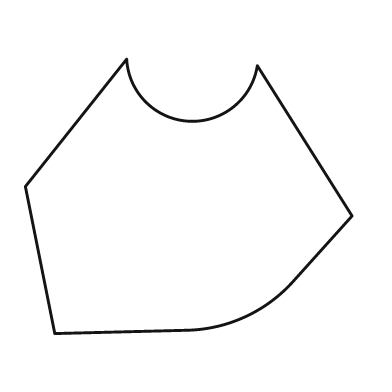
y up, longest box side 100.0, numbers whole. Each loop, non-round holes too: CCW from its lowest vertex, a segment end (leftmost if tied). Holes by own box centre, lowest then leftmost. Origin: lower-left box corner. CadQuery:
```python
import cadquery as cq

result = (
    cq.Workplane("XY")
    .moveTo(9.0, 0.0)
    .lineTo(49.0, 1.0)
    .threePointArc((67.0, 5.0), (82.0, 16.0))
    .lineTo(100.0, 36.0)
    .lineTo(71.0, 82.0)
    .threePointArc((50.0, 65.0), (31.0, 84.0))
    .lineTo(0.0, 45.0)
    .close()
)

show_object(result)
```